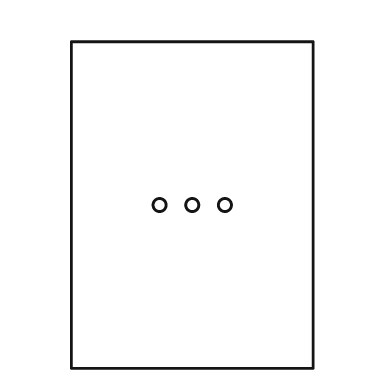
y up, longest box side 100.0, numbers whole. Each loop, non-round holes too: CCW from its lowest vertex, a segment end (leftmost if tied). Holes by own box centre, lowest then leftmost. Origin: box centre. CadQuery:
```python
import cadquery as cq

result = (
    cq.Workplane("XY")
    .moveTo(-37.0, -50.0)
    .lineTo(37.0, -50.0)
    .lineTo(37.0, 50.0)
    .lineTo(-37.0, 50.0)
    .close()
    .moveTo(-10.0, 0.0)
    .circle(2.0)
    .moveTo(0.0, 0.0)
    .circle(2.0)
    .moveTo(10.0, 0.0)
    .circle(2.0)
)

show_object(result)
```